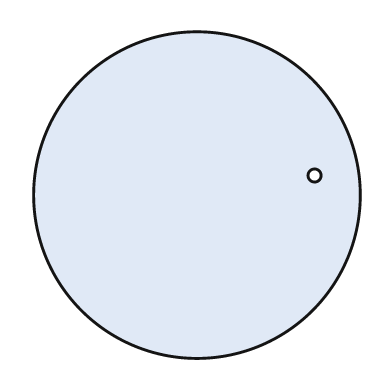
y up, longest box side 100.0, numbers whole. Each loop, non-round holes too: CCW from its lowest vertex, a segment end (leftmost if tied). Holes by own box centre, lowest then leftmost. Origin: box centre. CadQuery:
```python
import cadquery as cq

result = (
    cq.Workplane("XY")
    .moveTo(0.0, 0.0)
    .circle(50.0)
    .moveTo(36.0, 6.0)
    .circle(2.0)
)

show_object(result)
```